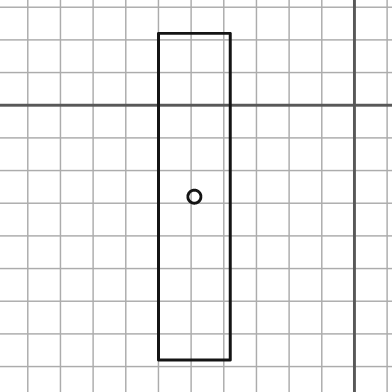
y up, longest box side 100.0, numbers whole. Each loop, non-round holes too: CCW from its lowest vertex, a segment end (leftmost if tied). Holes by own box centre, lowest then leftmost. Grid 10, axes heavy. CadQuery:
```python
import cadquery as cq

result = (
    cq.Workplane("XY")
    .moveTo(-60.0, -78.0)
    .lineTo(-38.0, -78.0)
    .lineTo(-38.0, 22.0)
    .lineTo(-60.0, 22.0)
    .close()
    .moveTo(-49.0, -28.0)
    .circle(2.0)
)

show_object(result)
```